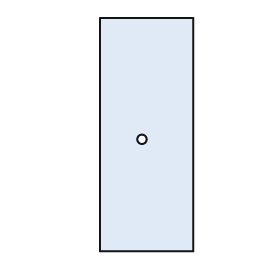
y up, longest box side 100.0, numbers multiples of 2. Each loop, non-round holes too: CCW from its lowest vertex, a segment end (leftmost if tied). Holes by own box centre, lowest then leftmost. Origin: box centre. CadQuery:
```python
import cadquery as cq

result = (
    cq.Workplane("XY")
    .moveTo(-20.0, -50.0)
    .lineTo(20.0, -50.0)
    .lineTo(20.0, 50.0)
    .lineTo(-20.0, 50.0)
    .close()
    .moveTo(-2.0, -2.0)
    .circle(2.0)
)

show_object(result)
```